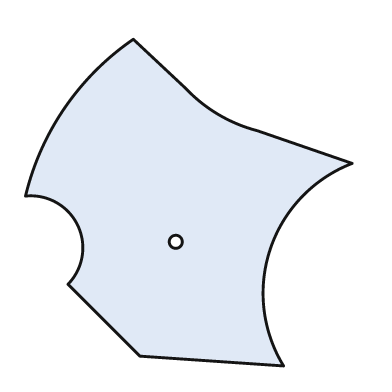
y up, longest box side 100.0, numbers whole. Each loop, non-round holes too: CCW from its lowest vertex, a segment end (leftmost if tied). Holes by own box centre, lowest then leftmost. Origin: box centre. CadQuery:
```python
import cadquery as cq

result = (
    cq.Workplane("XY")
    .moveTo(29.0, -50.0)
    .threePointArc((25.0, -14.0), (50.0, 12.0))
    .lineTo(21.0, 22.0)
    .threePointArc((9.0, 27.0), (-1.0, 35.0))
    .lineTo(-17.0, 50.0)
    .threePointArc((-38.0, 29.0), (-50.0, 2.0))
    .threePointArc((-34.0, -7.0), (-37.0, -25.0))
    .lineTo(-15.0, -47.0)
    .close()
    .moveTo(-4.0, -12.0)
    .circle(2.0)
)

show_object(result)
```